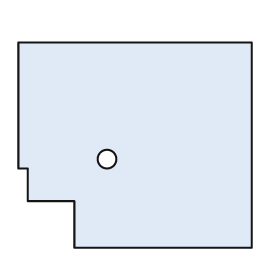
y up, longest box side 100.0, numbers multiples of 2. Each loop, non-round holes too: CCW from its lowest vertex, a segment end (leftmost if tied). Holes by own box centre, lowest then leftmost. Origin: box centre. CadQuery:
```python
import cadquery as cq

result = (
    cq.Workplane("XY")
    .moveTo(-26.0, -44.0)
    .lineTo(50.0, -44.0)
    .lineTo(50.0, 44.0)
    .lineTo(-50.0, 44.0)
    .lineTo(-50.0, -10.0)
    .lineTo(-46.0, -10.0)
    .lineTo(-46.0, -24.0)
    .lineTo(-26.0, -24.0)
    .close()
    .moveTo(-12.0, -6.0)
    .circle(4.0)
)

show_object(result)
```